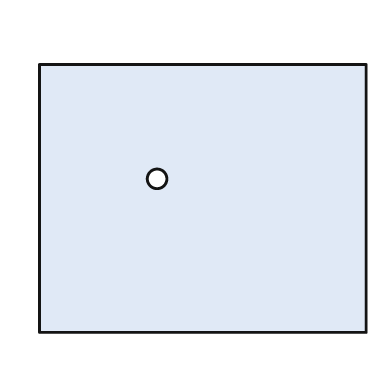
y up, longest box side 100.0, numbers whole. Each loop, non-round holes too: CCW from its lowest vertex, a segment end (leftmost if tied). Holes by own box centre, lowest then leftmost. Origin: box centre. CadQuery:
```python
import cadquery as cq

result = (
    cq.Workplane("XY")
    .moveTo(-50.0, -41.0)
    .lineTo(50.0, -41.0)
    .lineTo(50.0, 41.0)
    .lineTo(-50.0, 41.0)
    .close()
    .moveTo(-14.0, 6.0)
    .circle(3.0)
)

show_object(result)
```